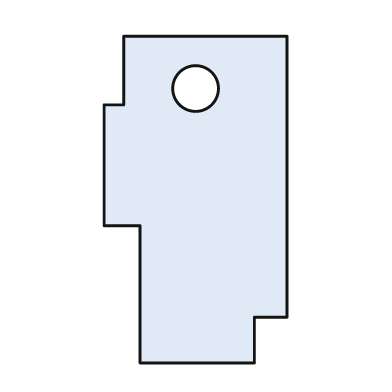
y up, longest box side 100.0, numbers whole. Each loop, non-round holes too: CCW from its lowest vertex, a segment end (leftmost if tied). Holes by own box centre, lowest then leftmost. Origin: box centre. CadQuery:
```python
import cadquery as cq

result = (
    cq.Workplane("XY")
    .moveTo(-17.0, -50.0)
    .lineTo(18.0, -50.0)
    .lineTo(18.0, -36.0)
    .lineTo(28.0, -36.0)
    .lineTo(28.0, 50.0)
    .lineTo(-22.0, 50.0)
    .lineTo(-22.0, 29.0)
    .lineTo(-28.0, 29.0)
    .lineTo(-28.0, -8.0)
    .lineTo(-17.0, -8.0)
    .close()
    .moveTo(0.0, 34.0)
    .circle(7.0)
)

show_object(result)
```